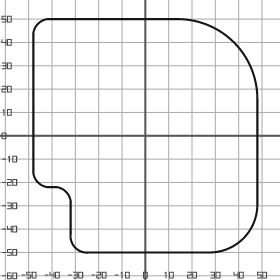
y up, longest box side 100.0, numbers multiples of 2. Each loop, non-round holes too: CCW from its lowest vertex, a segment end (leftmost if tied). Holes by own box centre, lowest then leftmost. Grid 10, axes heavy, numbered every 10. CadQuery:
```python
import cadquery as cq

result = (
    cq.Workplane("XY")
    .moveTo(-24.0, -50.0)
    .lineTo(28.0, -50.0)
    .threePointArc((42.0, -44.0), (48.0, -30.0))
    .lineTo(48.0, 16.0)
    .threePointArc((38.0, 40.0), (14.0, 50.0))
    .lineTo(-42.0, 50.0)
    .threePointArc((-46.0, 48.0), (-48.0, 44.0))
    .lineTo(-48.0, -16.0)
    .threePointArc((-46.0, -20.0), (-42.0, -22.0))
    .lineTo(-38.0, -22.0)
    .threePointArc((-34.0, -24.0), (-32.0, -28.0))
    .lineTo(-32.0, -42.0)
    .threePointArc((-30.0, -48.0), (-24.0, -50.0))
    .close()
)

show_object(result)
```